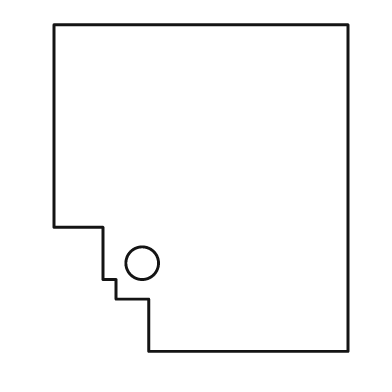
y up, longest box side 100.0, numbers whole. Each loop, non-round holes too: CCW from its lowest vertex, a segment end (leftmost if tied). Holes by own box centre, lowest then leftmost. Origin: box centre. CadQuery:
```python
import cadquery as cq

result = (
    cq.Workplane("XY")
    .moveTo(-16.0, -50.0)
    .lineTo(45.0, -50.0)
    .lineTo(45.0, 50.0)
    .lineTo(-45.0, 50.0)
    .lineTo(-45.0, -12.0)
    .lineTo(-30.0, -12.0)
    .lineTo(-30.0, -28.0)
    .lineTo(-26.0, -28.0)
    .lineTo(-26.0, -34.0)
    .lineTo(-16.0, -34.0)
    .close()
    .moveTo(-18.0, -23.0)
    .circle(5.0)
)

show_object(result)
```